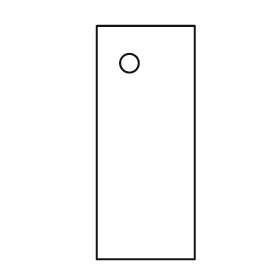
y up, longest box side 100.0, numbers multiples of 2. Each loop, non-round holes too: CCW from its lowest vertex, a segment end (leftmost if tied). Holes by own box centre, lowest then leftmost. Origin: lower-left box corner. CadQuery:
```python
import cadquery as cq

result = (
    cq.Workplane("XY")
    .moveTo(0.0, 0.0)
    .lineTo(42.0, 0.0)
    .lineTo(42.0, 100.0)
    .lineTo(0.0, 100.0)
    .close()
    .moveTo(14.0, 84.0)
    .circle(4.0)
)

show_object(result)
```